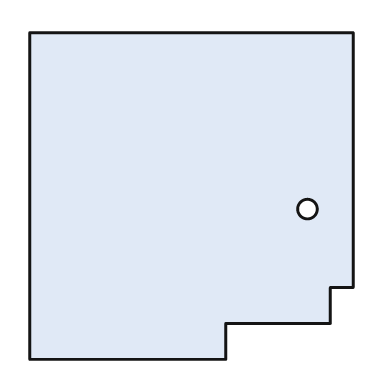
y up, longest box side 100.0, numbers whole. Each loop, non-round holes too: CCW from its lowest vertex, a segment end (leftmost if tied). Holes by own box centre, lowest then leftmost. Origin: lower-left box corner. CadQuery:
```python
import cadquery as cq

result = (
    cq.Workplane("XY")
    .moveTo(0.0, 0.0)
    .lineTo(60.0, 0.0)
    .lineTo(60.0, 11.0)
    .lineTo(92.0, 11.0)
    .lineTo(92.0, 22.0)
    .lineTo(99.0, 22.0)
    .lineTo(99.0, 100.0)
    .lineTo(0.0, 100.0)
    .close()
    .moveTo(85.0, 46.0)
    .circle(3.0)
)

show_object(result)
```